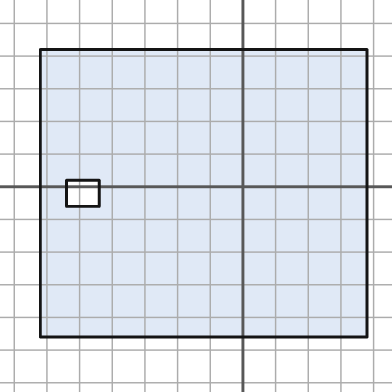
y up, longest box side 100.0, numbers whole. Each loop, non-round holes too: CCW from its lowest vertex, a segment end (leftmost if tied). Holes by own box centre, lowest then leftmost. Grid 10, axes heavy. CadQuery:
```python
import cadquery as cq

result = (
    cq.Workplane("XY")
    .moveTo(-62.0, -46.0)
    .lineTo(38.0, -46.0)
    .lineTo(38.0, 42.0)
    .lineTo(-62.0, 42.0)
    .close()
    .moveTo(-54.0, -6.0)
    .lineTo(-44.0, -6.0)
    .lineTo(-44.0, 2.0)
    .lineTo(-54.0, 2.0)
    .close()
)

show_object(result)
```